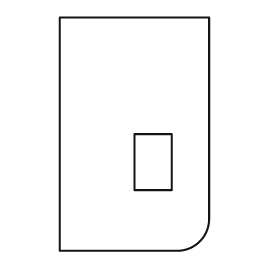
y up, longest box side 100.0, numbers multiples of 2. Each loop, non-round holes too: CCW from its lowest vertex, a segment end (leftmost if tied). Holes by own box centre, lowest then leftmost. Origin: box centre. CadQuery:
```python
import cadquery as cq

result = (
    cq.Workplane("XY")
    .moveTo(-32.0, -50.0)
    .lineTo(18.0, -50.0)
    .threePointArc((28.0, -46.0), (32.0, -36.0))
    .lineTo(32.0, 50.0)
    .lineTo(-32.0, 50.0)
    .close()
    .moveTo(0.0, -24.0)
    .lineTo(16.0, -24.0)
    .lineTo(16.0, 0.0)
    .lineTo(0.0, 0.0)
    .close()
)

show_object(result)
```